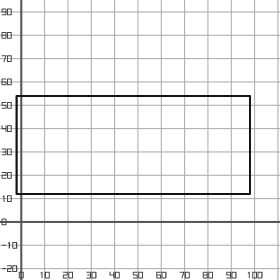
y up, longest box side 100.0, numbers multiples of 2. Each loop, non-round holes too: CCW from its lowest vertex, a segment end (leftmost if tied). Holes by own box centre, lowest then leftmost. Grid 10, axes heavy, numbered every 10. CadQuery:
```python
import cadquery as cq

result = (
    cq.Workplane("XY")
    .moveTo(-2.0, 12.0)
    .lineTo(98.0, 12.0)
    .lineTo(98.0, 54.0)
    .lineTo(-2.0, 54.0)
    .close()
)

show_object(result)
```